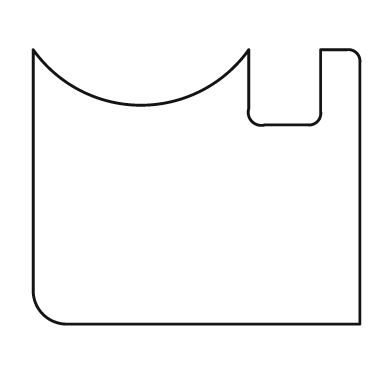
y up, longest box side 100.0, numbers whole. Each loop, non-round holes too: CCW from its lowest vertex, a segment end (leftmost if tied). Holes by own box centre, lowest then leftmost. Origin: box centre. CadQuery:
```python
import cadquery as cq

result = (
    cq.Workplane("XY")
    .moveTo(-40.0, -42.0)
    .lineTo(50.0, -42.0)
    .lineTo(50.0, 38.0)
    .threePointArc((49.0, 41.0), (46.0, 42.0))
    .lineTo(38.0, 42.0)
    .lineTo(38.0, 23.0)
    .threePointArc((37.0, 20.0), (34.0, 19.0))
    .lineTo(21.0, 19.0)
    .threePointArc((17.0, 20.0), (16.0, 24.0))
    .lineTo(16.0, 42.0)
    .threePointArc((-17.0, 25.0), (-50.0, 42.0))
    .lineTo(-50.0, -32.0)
    .threePointArc((-47.0, -39.0), (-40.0, -42.0))
    .close()
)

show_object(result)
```